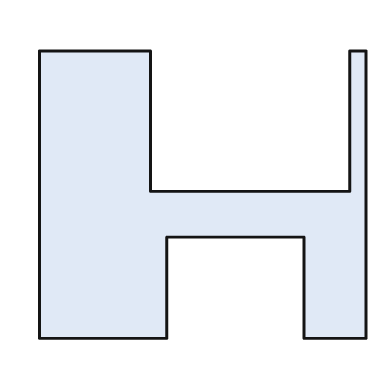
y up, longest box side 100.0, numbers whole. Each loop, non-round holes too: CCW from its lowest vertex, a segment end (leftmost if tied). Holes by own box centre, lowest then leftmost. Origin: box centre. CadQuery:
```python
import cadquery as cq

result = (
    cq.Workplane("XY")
    .moveTo(-50.0, -44.0)
    .lineTo(-11.0, -44.0)
    .lineTo(-11.0, -13.0)
    .lineTo(31.0, -13.0)
    .lineTo(31.0, -44.0)
    .lineTo(50.0, -44.0)
    .lineTo(50.0, 44.0)
    .lineTo(45.0, 44.0)
    .lineTo(45.0, 1.0)
    .lineTo(-16.0, 1.0)
    .lineTo(-16.0, 44.0)
    .lineTo(-50.0, 44.0)
    .close()
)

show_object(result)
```